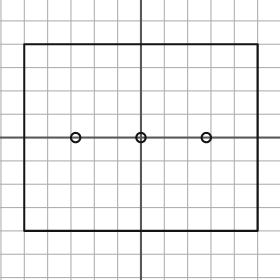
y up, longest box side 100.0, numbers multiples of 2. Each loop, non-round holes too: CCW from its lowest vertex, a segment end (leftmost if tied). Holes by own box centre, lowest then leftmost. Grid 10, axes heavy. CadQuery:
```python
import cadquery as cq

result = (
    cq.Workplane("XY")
    .moveTo(-50.0, -40.0)
    .lineTo(50.0, -40.0)
    .lineTo(50.0, 40.0)
    .lineTo(-50.0, 40.0)
    .close()
    .moveTo(-28.0, 0.0)
    .circle(2.0)
    .moveTo(0.0, 0.0)
    .circle(2.0)
    .moveTo(28.0, 0.0)
    .circle(2.0)
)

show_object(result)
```